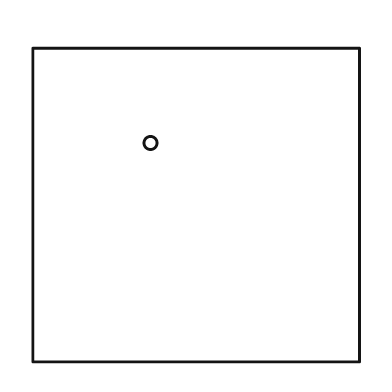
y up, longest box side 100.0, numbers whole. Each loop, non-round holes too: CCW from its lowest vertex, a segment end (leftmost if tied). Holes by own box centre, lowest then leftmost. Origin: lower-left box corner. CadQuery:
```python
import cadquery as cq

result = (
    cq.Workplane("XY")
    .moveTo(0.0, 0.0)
    .lineTo(100.0, 0.0)
    .lineTo(100.0, 96.0)
    .lineTo(0.0, 96.0)
    .close()
    .moveTo(36.0, 67.0)
    .circle(2.0)
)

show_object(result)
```